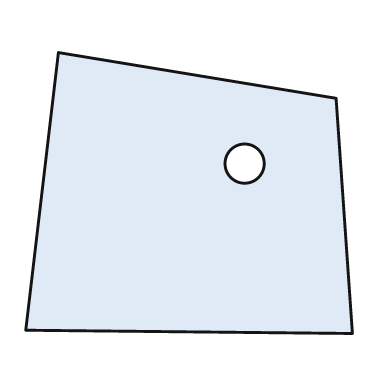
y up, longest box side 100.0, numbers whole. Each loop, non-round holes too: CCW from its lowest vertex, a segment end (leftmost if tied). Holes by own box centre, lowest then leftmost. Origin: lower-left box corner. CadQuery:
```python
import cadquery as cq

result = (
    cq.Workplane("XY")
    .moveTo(100.0, 0.0)
    .lineTo(95.0, 72.0)
    .lineTo(10.0, 86.0)
    .lineTo(0.0, 1.0)
    .close()
    .moveTo(67.0, 52.0)
    .circle(6.0)
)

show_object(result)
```